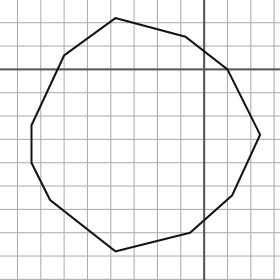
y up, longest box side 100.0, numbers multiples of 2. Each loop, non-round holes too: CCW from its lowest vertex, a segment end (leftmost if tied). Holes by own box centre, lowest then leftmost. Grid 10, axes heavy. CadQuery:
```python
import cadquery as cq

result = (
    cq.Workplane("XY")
    .moveTo(-38.0, -78.0)
    .lineTo(-6.0, -70.0)
    .lineTo(12.0, -54.0)
    .lineTo(24.0, -28.0)
    .lineTo(10.0, 0.0)
    .lineTo(-8.0, 14.0)
    .lineTo(-38.0, 22.0)
    .lineTo(-60.0, 6.0)
    .lineTo(-74.0, -24.0)
    .lineTo(-74.0, -40.0)
    .lineTo(-66.0, -56.0)
    .close()
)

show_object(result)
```